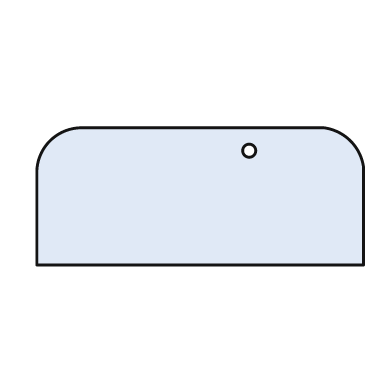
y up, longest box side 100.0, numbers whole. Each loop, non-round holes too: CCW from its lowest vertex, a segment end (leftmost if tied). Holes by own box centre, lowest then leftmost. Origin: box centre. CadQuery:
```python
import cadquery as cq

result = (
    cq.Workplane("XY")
    .moveTo(-50.0, -21.0)
    .lineTo(50.0, -21.0)
    .lineTo(50.0, 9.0)
    .threePointArc((46.0, 17.0), (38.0, 21.0))
    .lineTo(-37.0, 21.0)
    .threePointArc((-46.0, 17.0), (-50.0, 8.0))
    .close()
    .moveTo(15.0, 14.0)
    .circle(2.0)
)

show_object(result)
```